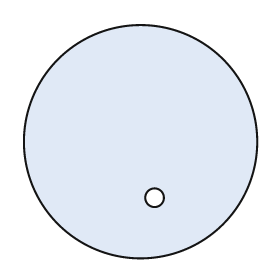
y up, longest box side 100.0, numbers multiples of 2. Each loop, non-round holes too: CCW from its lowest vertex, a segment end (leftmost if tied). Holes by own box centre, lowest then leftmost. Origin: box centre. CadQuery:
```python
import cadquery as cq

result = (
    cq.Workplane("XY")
    .moveTo(0.0, 0.0)
    .circle(50.0)
    .moveTo(6.0, -24.0)
    .circle(4.0)
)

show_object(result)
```